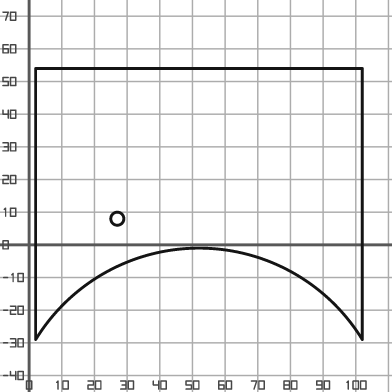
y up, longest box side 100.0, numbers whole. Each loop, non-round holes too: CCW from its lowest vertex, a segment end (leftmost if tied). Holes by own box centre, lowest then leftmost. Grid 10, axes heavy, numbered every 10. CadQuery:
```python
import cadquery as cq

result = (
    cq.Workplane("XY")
    .moveTo(2.0, -29.0)
    .threePointArc((52.0, -1.0), (102.0, -29.0))
    .lineTo(102.0, 54.0)
    .lineTo(2.0, 54.0)
    .close()
    .moveTo(27.0, 8.0)
    .circle(2.0)
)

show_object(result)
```